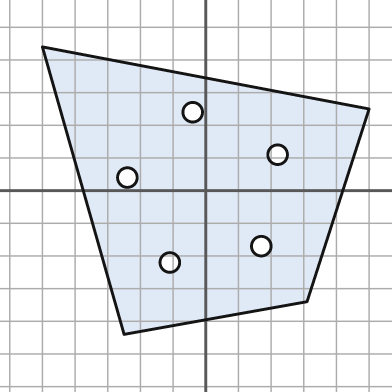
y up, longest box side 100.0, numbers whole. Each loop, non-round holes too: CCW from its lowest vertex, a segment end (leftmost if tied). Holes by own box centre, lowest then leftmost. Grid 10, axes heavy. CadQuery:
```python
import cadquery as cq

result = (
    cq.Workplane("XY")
    .moveTo(-25.0, -44.0)
    .lineTo(31.0, -34.0)
    .lineTo(50.0, 25.0)
    .lineTo(-50.0, 44.0)
    .close()
    .moveTo(-11.0, -22.0)
    .circle(3.0)
    .moveTo(17.0, -17.0)
    .circle(3.0)
    .moveTo(-24.0, 4.0)
    .circle(3.0)
    .moveTo(22.0, 11.0)
    .circle(3.0)
    .moveTo(-4.0, 24.0)
    .circle(3.0)
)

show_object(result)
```